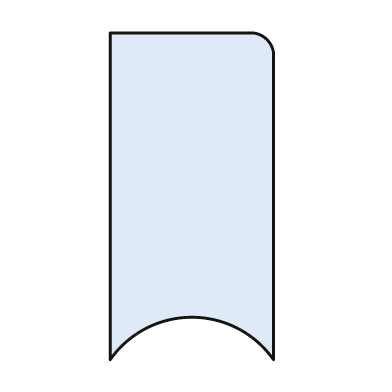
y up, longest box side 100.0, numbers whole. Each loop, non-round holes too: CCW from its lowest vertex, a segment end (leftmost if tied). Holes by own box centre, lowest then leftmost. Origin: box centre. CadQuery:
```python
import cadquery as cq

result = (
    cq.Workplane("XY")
    .moveTo(-25.0, -50.0)
    .threePointArc((0.0, -37.0), (25.0, -50.0))
    .lineTo(25.0, 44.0)
    .threePointArc((23.0, 48.0), (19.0, 50.0))
    .lineTo(-25.0, 50.0)
    .close()
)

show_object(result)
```